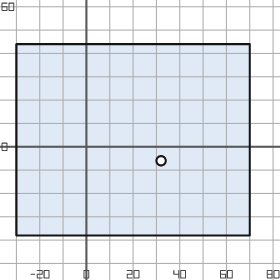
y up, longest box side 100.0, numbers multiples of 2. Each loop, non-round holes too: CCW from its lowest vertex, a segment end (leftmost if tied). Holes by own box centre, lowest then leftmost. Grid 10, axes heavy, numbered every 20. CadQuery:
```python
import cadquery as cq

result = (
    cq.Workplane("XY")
    .moveTo(-30.0, -38.0)
    .lineTo(70.0, -38.0)
    .lineTo(70.0, 44.0)
    .lineTo(-30.0, 44.0)
    .close()
    .moveTo(32.0, -6.0)
    .circle(2.0)
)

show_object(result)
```